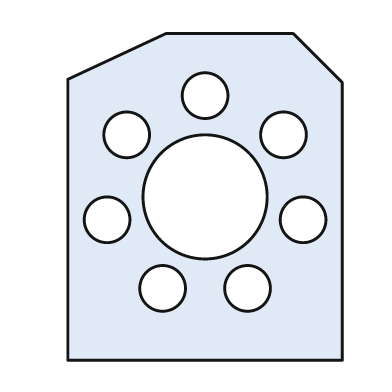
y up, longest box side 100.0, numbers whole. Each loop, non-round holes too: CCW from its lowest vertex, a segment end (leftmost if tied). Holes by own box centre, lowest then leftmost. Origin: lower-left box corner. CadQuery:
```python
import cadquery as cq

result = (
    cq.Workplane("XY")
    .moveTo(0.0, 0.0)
    .lineTo(84.0, 0.0)
    .lineTo(84.0, 85.0)
    .lineTo(69.0, 100.0)
    .lineTo(30.0, 100.0)
    .lineTo(0.0, 86.0)
    .close()
    .moveTo(29.0, 22.0)
    .circle(7.0)
    .moveTo(55.0, 22.0)
    .circle(7.0)
    .moveTo(12.0, 43.0)
    .circle(7.0)
    .moveTo(72.0, 43.0)
    .circle(7.0)
    .moveTo(42.0, 50.0)
    .circle(19.0)
    .moveTo(18.0, 69.0)
    .circle(7.0)
    .moveTo(66.0, 69.0)
    .circle(7.0)
    .moveTo(42.0, 81.0)
    .circle(7.0)
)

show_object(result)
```